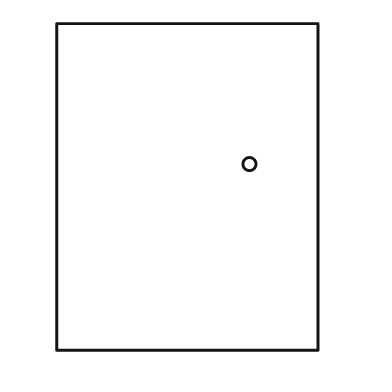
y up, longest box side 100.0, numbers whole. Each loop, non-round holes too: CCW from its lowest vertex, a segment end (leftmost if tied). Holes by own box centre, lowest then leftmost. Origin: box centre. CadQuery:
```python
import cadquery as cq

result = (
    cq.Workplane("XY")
    .moveTo(-40.0, -50.0)
    .lineTo(40.0, -50.0)
    .lineTo(40.0, 50.0)
    .lineTo(-40.0, 50.0)
    .close()
    .moveTo(19.0, 7.0)
    .circle(2.0)
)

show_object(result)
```